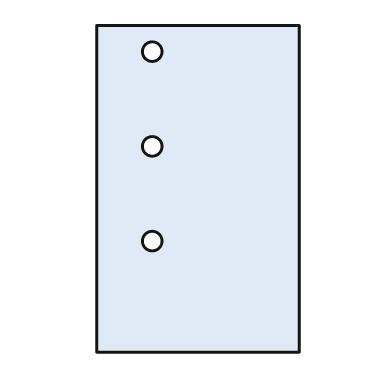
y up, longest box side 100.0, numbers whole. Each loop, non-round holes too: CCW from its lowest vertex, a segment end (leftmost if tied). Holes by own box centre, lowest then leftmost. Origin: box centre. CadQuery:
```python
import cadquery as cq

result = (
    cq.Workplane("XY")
    .moveTo(-31.0, -50.0)
    .lineTo(31.0, -50.0)
    .lineTo(31.0, 50.0)
    .lineTo(-31.0, 50.0)
    .close()
    .moveTo(-14.0, -16.0)
    .circle(3.0)
    .moveTo(-14.0, 13.0)
    .circle(3.0)
    .moveTo(-14.0, 42.0)
    .circle(3.0)
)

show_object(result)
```